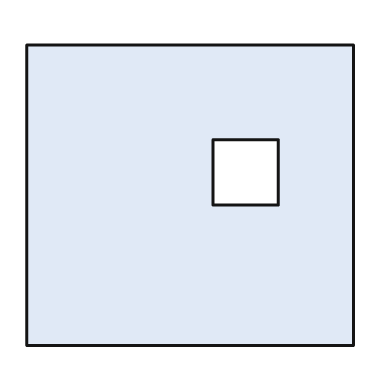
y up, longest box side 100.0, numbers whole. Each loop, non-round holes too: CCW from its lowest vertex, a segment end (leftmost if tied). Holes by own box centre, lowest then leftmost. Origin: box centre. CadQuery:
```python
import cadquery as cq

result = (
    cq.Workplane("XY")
    .moveTo(-50.0, -46.0)
    .lineTo(50.0, -46.0)
    .lineTo(50.0, 46.0)
    .lineTo(-50.0, 46.0)
    .close()
    .moveTo(7.0, -3.0)
    .lineTo(27.0, -3.0)
    .lineTo(27.0, 17.0)
    .lineTo(7.0, 17.0)
    .close()
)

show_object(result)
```